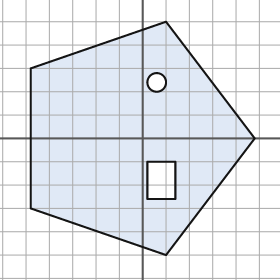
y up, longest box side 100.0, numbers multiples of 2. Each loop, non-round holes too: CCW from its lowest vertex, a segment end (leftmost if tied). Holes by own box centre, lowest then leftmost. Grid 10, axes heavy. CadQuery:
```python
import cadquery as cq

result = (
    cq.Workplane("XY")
    .moveTo(10.0, -50.0)
    .lineTo(48.0, 0.0)
    .lineTo(10.0, 50.0)
    .lineTo(-48.0, 30.0)
    .lineTo(-48.0, -30.0)
    .close()
    .moveTo(2.0, -26.0)
    .lineTo(14.0, -26.0)
    .lineTo(14.0, -10.0)
    .lineTo(2.0, -10.0)
    .close()
    .moveTo(6.0, 24.0)
    .circle(4.0)
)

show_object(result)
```